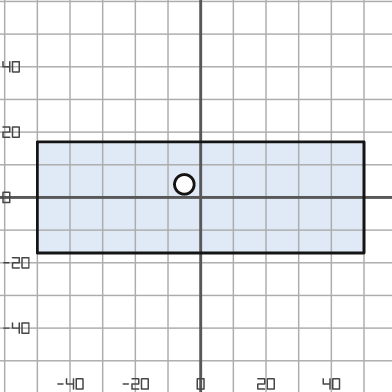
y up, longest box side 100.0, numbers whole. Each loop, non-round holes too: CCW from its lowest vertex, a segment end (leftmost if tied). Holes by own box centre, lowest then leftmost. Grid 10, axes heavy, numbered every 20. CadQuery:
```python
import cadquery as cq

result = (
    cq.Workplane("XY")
    .moveTo(-50.0, -17.0)
    .lineTo(50.0, -17.0)
    .lineTo(50.0, 17.0)
    .lineTo(-50.0, 17.0)
    .close()
    .moveTo(-5.0, 4.0)
    .circle(3.0)
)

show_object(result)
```